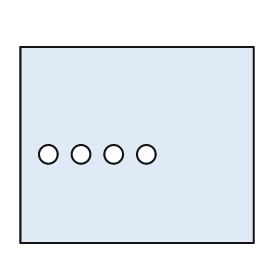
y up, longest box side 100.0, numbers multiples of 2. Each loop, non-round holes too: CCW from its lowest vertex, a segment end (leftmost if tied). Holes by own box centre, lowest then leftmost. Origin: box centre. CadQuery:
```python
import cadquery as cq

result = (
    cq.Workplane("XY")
    .moveTo(-50.0, -42.0)
    .lineTo(50.0, -42.0)
    .lineTo(50.0, 42.0)
    .lineTo(-50.0, 42.0)
    .close()
    .moveTo(-38.0, -4.0)
    .circle(4.0)
    .moveTo(-24.0, -4.0)
    .circle(4.0)
    .moveTo(-10.0, -4.0)
    .circle(4.0)
    .moveTo(4.0, -4.0)
    .circle(4.0)
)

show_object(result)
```